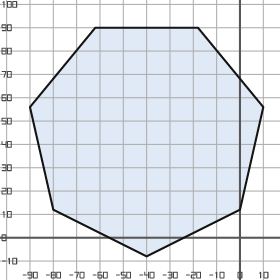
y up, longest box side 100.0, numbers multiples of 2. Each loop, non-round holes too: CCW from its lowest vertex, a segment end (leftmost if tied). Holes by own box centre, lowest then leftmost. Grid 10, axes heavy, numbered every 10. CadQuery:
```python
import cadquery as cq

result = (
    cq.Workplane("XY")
    .moveTo(-40.0, -8.0)
    .lineTo(0.0, 12.0)
    .lineTo(10.0, 56.0)
    .lineTo(-18.0, 90.0)
    .lineTo(-62.0, 90.0)
    .lineTo(-90.0, 56.0)
    .lineTo(-80.0, 12.0)
    .close()
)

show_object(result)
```